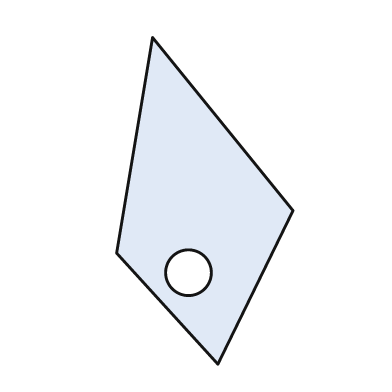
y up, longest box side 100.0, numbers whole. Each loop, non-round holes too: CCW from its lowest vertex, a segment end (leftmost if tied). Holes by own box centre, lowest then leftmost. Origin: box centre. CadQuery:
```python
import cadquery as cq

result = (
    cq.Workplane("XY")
    .moveTo(4.0, -50.0)
    .lineTo(27.0, -3.0)
    .lineTo(-16.0, 50.0)
    .lineTo(-27.0, -16.0)
    .close()
    .moveTo(-5.0, -22.0)
    .circle(7.0)
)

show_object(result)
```